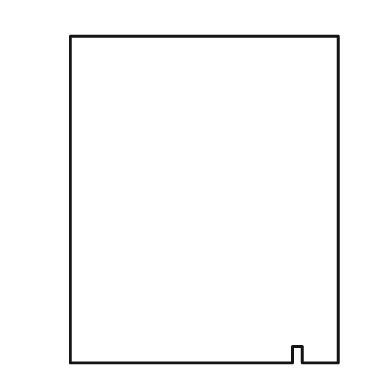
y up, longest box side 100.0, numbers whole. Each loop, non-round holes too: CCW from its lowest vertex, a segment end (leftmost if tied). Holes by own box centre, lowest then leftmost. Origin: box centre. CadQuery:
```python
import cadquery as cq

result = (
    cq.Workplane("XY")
    .moveTo(-41.0, -50.0)
    .lineTo(27.0, -50.0)
    .lineTo(27.0, -45.0)
    .lineTo(30.0, -45.0)
    .lineTo(30.0, -50.0)
    .lineTo(41.0, -50.0)
    .lineTo(41.0, 50.0)
    .lineTo(-41.0, 50.0)
    .close()
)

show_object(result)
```